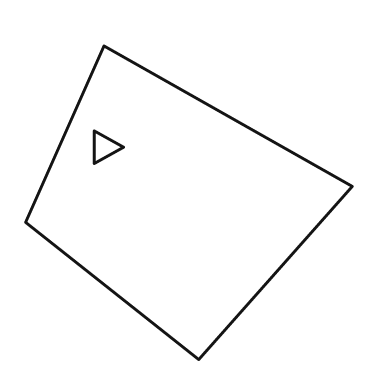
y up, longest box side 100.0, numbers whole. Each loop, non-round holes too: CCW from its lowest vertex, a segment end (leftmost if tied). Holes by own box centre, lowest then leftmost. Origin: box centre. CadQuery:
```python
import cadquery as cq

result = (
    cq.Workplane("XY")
    .moveTo(3.0, -48.0)
    .lineTo(50.0, 5.0)
    .lineTo(-26.0, 48.0)
    .lineTo(-50.0, -6.0)
    .close()
    .moveTo(-29.0, 12.0)
    .lineTo(-20.0, 17.0)
    .lineTo(-29.0, 22.0)
    .close()
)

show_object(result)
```